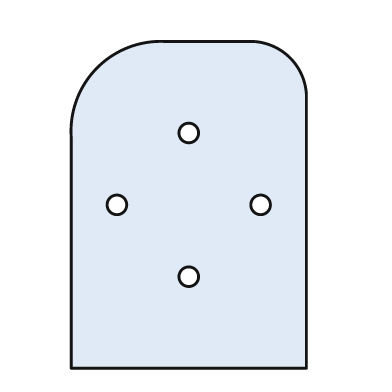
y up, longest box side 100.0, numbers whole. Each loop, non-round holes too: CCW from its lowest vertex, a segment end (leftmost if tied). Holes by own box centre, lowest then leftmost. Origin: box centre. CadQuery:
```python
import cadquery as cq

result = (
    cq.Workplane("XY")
    .moveTo(-36.0, -50.0)
    .lineTo(36.0, -50.0)
    .lineTo(36.0, 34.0)
    .threePointArc((31.0, 45.0), (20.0, 50.0))
    .lineTo(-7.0, 50.0)
    .threePointArc((-28.0, 42.0), (-36.0, 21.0))
    .close()
    .moveTo(0.0, -22.0)
    .circle(3.0)
    .moveTo(-22.0, 0.0)
    .circle(3.0)
    .moveTo(22.0, 0.0)
    .circle(3.0)
    .moveTo(0.0, 22.0)
    .circle(3.0)
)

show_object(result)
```